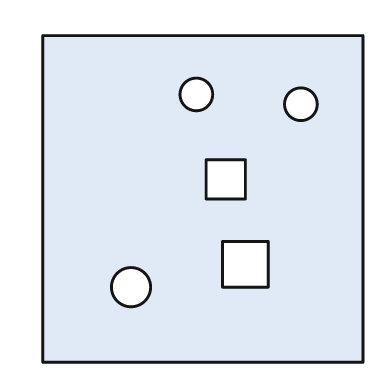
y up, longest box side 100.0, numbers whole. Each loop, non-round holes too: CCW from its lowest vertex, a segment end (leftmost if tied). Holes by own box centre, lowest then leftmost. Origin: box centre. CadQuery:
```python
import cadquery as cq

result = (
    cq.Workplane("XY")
    .moveTo(-49.0, -50.0)
    .lineTo(49.0, -50.0)
    .lineTo(49.0, 50.0)
    .lineTo(-49.0, 50.0)
    .close()
    .moveTo(-22.0, -27.0)
    .circle(6.0)
    .moveTo(6.0, -27.0)
    .lineTo(20.0, -27.0)
    .lineTo(20.0, -13.0)
    .lineTo(6.0, -13.0)
    .close()
    .moveTo(1.0, 0.0)
    .lineTo(13.0, 0.0)
    .lineTo(13.0, 12.0)
    .lineTo(1.0, 12.0)
    .close()
    .moveTo(30.0, 29.0)
    .circle(5.0)
    .moveTo(-2.0, 32.0)
    .circle(5.0)
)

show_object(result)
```